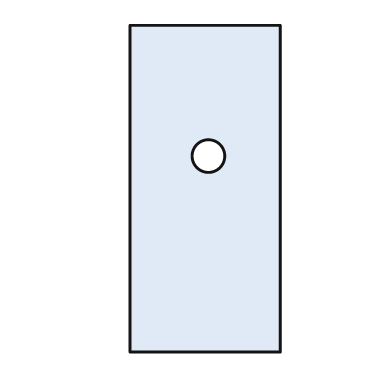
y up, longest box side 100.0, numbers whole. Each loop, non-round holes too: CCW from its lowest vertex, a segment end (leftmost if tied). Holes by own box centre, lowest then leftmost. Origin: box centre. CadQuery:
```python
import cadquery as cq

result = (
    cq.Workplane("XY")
    .moveTo(-23.0, -50.0)
    .lineTo(23.0, -50.0)
    .lineTo(23.0, 50.0)
    .lineTo(-23.0, 50.0)
    .close()
    .moveTo(1.0, 10.0)
    .circle(5.0)
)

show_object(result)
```